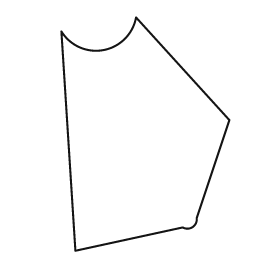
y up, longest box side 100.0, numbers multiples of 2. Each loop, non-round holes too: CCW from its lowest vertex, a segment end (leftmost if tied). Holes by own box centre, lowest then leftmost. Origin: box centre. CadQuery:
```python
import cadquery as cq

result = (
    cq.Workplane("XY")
    .moveTo(-30.0, -50.0)
    .lineTo(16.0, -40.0)
    .threePointArc((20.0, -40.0), (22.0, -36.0))
    .lineTo(36.0, 6.0)
    .lineTo(-4.0, 50.0)
    .threePointArc((-18.0, 36.0), (-36.0, 44.0))
    .close()
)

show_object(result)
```